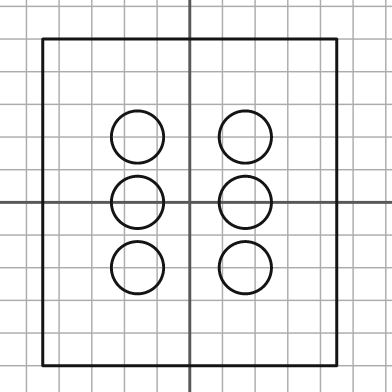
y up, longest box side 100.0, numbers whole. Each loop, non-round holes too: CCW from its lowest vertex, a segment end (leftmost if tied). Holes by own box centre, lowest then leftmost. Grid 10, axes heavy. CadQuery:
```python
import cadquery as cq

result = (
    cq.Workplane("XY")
    .moveTo(-45.0, -50.0)
    .lineTo(45.0, -50.0)
    .lineTo(45.0, 50.0)
    .lineTo(-45.0, 50.0)
    .close()
    .moveTo(-16.0, -20.0)
    .circle(8.0)
    .moveTo(17.0, -20.0)
    .circle(8.0)
    .moveTo(-16.0, 0.0)
    .circle(8.0)
    .moveTo(17.0, 0.0)
    .circle(8.0)
    .moveTo(-16.0, 20.0)
    .circle(8.0)
    .moveTo(17.0, 20.0)
    .circle(8.0)
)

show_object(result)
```